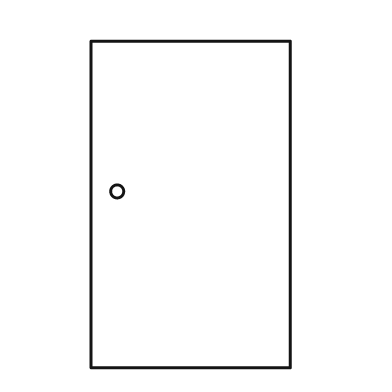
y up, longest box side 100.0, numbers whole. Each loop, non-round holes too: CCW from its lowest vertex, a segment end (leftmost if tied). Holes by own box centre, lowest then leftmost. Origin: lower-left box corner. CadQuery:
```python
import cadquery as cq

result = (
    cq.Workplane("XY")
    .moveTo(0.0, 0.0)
    .lineTo(61.0, 0.0)
    .lineTo(61.0, 100.0)
    .lineTo(0.0, 100.0)
    .close()
    .moveTo(8.0, 54.0)
    .circle(2.0)
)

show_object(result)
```